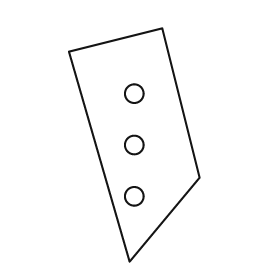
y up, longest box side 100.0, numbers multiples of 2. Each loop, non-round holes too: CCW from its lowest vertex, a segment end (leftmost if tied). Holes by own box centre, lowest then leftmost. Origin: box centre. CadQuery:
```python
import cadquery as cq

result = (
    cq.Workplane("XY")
    .moveTo(-2.0, -50.0)
    .lineTo(28.0, -14.0)
    .lineTo(12.0, 50.0)
    .lineTo(-28.0, 40.0)
    .close()
    .moveTo(0.0, -22.0)
    .circle(4.0)
    .moveTo(0.0, 0.0)
    .circle(4.0)
    .moveTo(0.0, 22.0)
    .circle(4.0)
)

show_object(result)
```